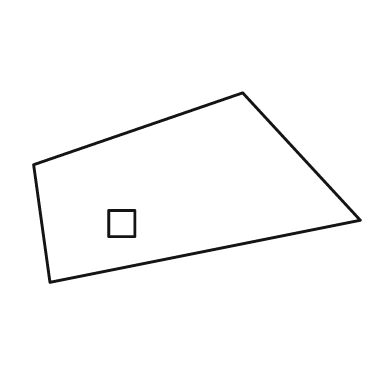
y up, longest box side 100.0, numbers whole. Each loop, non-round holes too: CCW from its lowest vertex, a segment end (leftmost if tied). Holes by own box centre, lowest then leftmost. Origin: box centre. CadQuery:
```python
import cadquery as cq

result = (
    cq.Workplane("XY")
    .moveTo(-45.0, -29.0)
    .lineTo(50.0, -10.0)
    .lineTo(14.0, 29.0)
    .lineTo(-50.0, 7.0)
    .close()
    .moveTo(-27.0, -15.0)
    .lineTo(-19.0, -15.0)
    .lineTo(-19.0, -7.0)
    .lineTo(-27.0, -7.0)
    .close()
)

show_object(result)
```